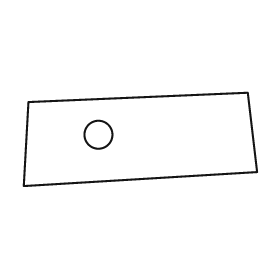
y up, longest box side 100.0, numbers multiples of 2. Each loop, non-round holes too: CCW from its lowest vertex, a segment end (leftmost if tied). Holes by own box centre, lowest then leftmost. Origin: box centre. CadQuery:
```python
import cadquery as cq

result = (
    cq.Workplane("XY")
    .moveTo(-50.0, -20.0)
    .lineTo(50.0, -14.0)
    .lineTo(46.0, 20.0)
    .lineTo(-48.0, 16.0)
    .close()
    .moveTo(-18.0, 2.0)
    .circle(6.0)
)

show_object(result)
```